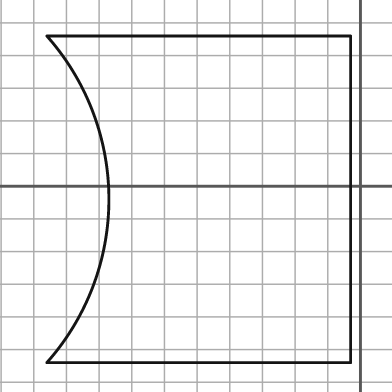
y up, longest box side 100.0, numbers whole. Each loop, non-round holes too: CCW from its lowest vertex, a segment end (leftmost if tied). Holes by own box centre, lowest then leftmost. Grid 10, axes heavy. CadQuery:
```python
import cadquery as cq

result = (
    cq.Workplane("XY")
    .moveTo(-96.0, -54.0)
    .lineTo(-3.0, -54.0)
    .lineTo(-3.0, 46.0)
    .lineTo(-96.0, 46.0)
    .threePointArc((-77.0, -4.0), (-96.0, -54.0))
    .close()
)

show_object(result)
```